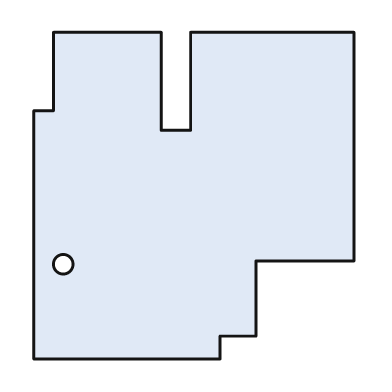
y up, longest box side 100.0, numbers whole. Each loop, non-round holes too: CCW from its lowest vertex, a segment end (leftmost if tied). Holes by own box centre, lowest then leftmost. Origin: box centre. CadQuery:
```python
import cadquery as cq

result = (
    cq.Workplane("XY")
    .moveTo(-49.0, -50.0)
    .lineTo(8.0, -50.0)
    .lineTo(8.0, -43.0)
    .lineTo(19.0, -43.0)
    .lineTo(19.0, -20.0)
    .lineTo(49.0, -20.0)
    .lineTo(49.0, 50.0)
    .lineTo(-1.0, 50.0)
    .lineTo(-1.0, 20.0)
    .lineTo(-10.0, 20.0)
    .lineTo(-10.0, 50.0)
    .lineTo(-43.0, 50.0)
    .lineTo(-43.0, 26.0)
    .lineTo(-49.0, 26.0)
    .close()
    .moveTo(-40.0, -21.0)
    .circle(3.0)
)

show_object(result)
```